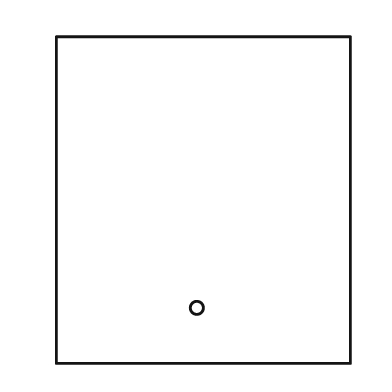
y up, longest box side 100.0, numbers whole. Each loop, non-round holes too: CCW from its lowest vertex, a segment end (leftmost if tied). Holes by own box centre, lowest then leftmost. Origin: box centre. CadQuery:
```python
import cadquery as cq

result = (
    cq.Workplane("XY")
    .moveTo(-45.0, -50.0)
    .lineTo(45.0, -50.0)
    .lineTo(45.0, 50.0)
    .lineTo(-45.0, 50.0)
    .close()
    .moveTo(-2.0, -33.0)
    .circle(2.0)
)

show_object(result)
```